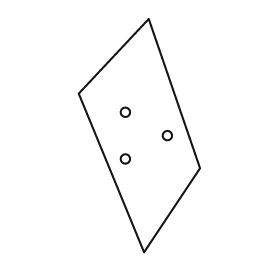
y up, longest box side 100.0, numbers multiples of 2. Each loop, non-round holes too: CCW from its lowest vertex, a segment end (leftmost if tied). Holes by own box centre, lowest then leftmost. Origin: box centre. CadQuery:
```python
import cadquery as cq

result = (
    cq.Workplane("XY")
    .moveTo(2.0, -50.0)
    .lineTo(26.0, -14.0)
    .lineTo(4.0, 50.0)
    .lineTo(-26.0, 18.0)
    .close()
    .moveTo(-6.0, -10.0)
    .circle(2.0)
    .moveTo(12.0, 0.0)
    .circle(2.0)
    .moveTo(-6.0, 10.0)
    .circle(2.0)
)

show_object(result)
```